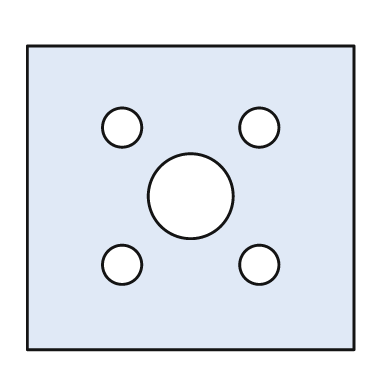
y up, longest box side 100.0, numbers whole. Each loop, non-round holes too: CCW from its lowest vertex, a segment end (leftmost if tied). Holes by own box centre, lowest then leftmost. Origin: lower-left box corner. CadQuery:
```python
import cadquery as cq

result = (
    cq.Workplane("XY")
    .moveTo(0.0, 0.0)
    .lineTo(100.0, 0.0)
    .lineTo(100.0, 93.0)
    .lineTo(0.0, 93.0)
    .close()
    .moveTo(29.0, 26.0)
    .circle(6.0)
    .moveTo(71.0, 26.0)
    .circle(6.0)
    .moveTo(50.0, 47.0)
    .circle(13.0)
    .moveTo(29.0, 68.0)
    .circle(6.0)
    .moveTo(71.0, 68.0)
    .circle(6.0)
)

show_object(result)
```